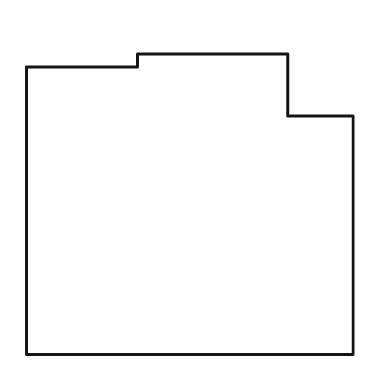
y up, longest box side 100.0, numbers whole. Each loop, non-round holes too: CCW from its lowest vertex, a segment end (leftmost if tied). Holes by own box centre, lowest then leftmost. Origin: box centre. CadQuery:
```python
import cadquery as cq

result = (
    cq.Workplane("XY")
    .moveTo(-50.0, -46.0)
    .lineTo(50.0, -46.0)
    .lineTo(50.0, 27.0)
    .lineTo(30.0, 27.0)
    .lineTo(30.0, 46.0)
    .lineTo(-16.0, 46.0)
    .lineTo(-16.0, 42.0)
    .lineTo(-50.0, 42.0)
    .close()
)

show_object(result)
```